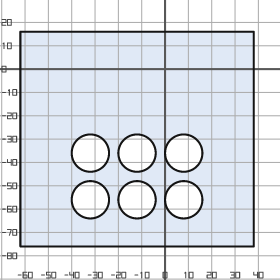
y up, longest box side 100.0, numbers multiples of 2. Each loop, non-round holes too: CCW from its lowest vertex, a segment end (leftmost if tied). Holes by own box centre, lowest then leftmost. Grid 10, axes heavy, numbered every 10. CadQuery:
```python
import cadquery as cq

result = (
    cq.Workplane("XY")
    .moveTo(-62.0, -76.0)
    .lineTo(38.0, -76.0)
    .lineTo(38.0, 16.0)
    .lineTo(-62.0, 16.0)
    .close()
    .moveTo(-32.0, -56.0)
    .circle(8.0)
    .moveTo(-12.0, -56.0)
    .circle(8.0)
    .moveTo(8.0, -56.0)
    .circle(8.0)
    .moveTo(-32.0, -36.0)
    .circle(8.0)
    .moveTo(-12.0, -36.0)
    .circle(8.0)
    .moveTo(8.0, -36.0)
    .circle(8.0)
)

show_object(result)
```